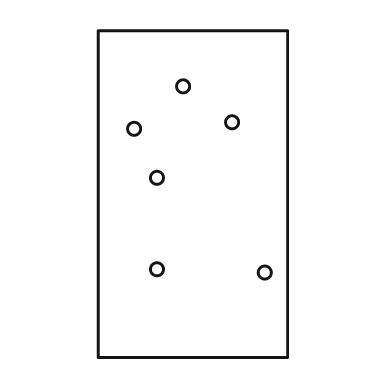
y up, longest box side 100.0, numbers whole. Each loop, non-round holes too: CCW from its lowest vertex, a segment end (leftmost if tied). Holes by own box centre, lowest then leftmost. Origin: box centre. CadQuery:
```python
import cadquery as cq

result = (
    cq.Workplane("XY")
    .moveTo(-29.0, -50.0)
    .lineTo(29.0, -50.0)
    .lineTo(29.0, 50.0)
    .lineTo(-29.0, 50.0)
    .close()
    .moveTo(22.0, -24.0)
    .circle(2.0)
    .moveTo(-11.0, -23.0)
    .circle(2.0)
    .moveTo(-11.0, 5.0)
    .circle(2.0)
    .moveTo(-18.0, 20.0)
    .circle(2.0)
    .moveTo(12.0, 22.0)
    .circle(2.0)
    .moveTo(-3.0, 33.0)
    .circle(2.0)
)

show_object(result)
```